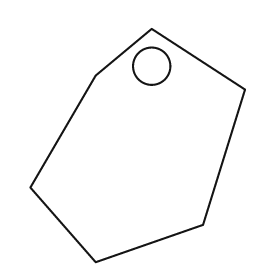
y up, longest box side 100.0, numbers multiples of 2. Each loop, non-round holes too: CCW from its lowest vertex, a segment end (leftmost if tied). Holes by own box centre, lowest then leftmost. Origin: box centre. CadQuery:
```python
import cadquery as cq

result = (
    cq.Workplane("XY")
    .moveTo(-18.0, -50.0)
    .lineTo(28.0, -34.0)
    .lineTo(46.0, 24.0)
    .lineTo(6.0, 50.0)
    .lineTo(-18.0, 30.0)
    .lineTo(-46.0, -18.0)
    .close()
    .moveTo(6.0, 34.0)
    .circle(8.0)
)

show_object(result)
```